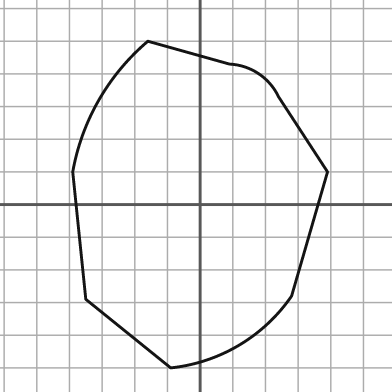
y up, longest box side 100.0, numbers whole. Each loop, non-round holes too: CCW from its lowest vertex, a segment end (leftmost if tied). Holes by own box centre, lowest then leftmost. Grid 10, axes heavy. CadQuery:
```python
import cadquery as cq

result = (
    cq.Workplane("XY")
    .moveTo(-9.0, -50.0)
    .threePointArc((12.0, -43.0), (28.0, -28.0))
    .lineTo(39.0, 10.0)
    .lineTo(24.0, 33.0)
    .threePointArc((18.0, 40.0), (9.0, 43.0))
    .lineTo(-16.0, 50.0)
    .threePointArc((-31.0, 32.0), (-39.0, 10.0))
    .lineTo(-35.0, -29.0)
    .close()
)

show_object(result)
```